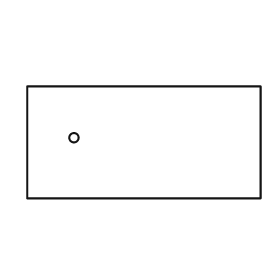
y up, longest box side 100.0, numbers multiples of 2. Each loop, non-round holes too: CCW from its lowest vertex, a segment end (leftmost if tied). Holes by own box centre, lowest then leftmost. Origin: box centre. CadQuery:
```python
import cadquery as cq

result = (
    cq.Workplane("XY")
    .moveTo(-50.0, -24.0)
    .lineTo(50.0, -24.0)
    .lineTo(50.0, 24.0)
    .lineTo(-50.0, 24.0)
    .close()
    .moveTo(-30.0, 2.0)
    .circle(2.0)
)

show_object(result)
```